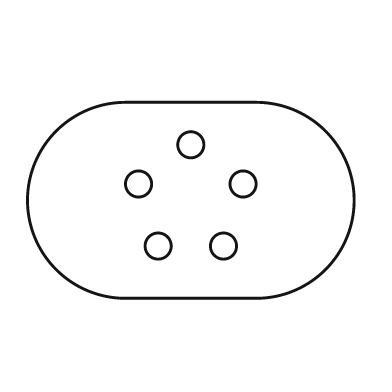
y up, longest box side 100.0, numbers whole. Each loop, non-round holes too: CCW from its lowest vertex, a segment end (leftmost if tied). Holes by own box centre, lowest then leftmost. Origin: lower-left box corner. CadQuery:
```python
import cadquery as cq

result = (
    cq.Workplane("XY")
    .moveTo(30.0, 0.0)
    .lineTo(70.0, 0.0)
    .threePointArc((100.0, 30.0), (70.0, 60.0))
    .lineTo(30.0, 60.0)
    .threePointArc((0.0, 30.0), (30.0, 0.0))
    .close()
    .moveTo(40.0, 16.0)
    .circle(4.0)
    .moveTo(60.0, 16.0)
    .circle(4.0)
    .moveTo(34.0, 35.0)
    .circle(4.0)
    .moveTo(66.0, 35.0)
    .circle(4.0)
    .moveTo(50.0, 47.0)
    .circle(4.0)
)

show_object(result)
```